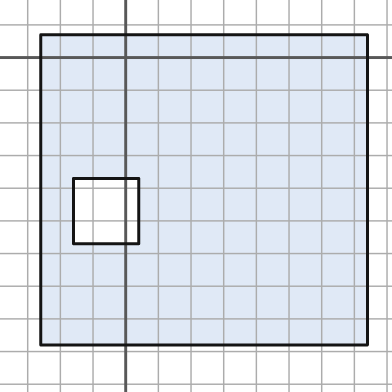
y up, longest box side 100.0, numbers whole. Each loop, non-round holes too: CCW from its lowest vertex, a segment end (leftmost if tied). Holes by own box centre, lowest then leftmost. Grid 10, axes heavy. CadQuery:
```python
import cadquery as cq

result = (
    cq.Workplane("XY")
    .moveTo(-26.0, -88.0)
    .lineTo(74.0, -88.0)
    .lineTo(74.0, 7.0)
    .lineTo(-26.0, 7.0)
    .close()
    .moveTo(-16.0, -57.0)
    .lineTo(4.0, -57.0)
    .lineTo(4.0, -37.0)
    .lineTo(-16.0, -37.0)
    .close()
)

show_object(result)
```